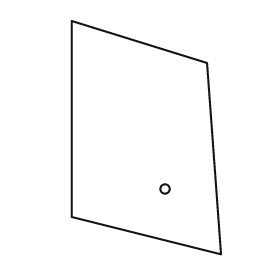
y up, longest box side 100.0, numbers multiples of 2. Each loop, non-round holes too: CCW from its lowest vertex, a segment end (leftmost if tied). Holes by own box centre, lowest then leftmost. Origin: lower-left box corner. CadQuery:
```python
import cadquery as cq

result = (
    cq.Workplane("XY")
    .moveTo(64.0, 0.0)
    .lineTo(58.0, 82.0)
    .lineTo(0.0, 100.0)
    .lineTo(0.0, 16.0)
    .close()
    .moveTo(40.0, 28.0)
    .circle(2.0)
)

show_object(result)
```